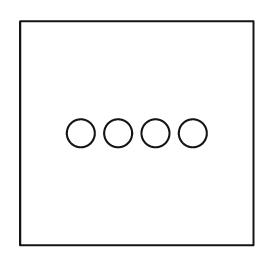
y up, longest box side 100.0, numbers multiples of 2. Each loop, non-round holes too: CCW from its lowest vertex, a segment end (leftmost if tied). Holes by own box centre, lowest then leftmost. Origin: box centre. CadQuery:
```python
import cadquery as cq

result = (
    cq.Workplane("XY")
    .moveTo(-50.0, -48.0)
    .lineTo(50.0, -48.0)
    .lineTo(50.0, 48.0)
    .lineTo(-50.0, 48.0)
    .close()
    .moveTo(-24.0, 0.0)
    .circle(6.0)
    .moveTo(-8.0, 0.0)
    .circle(6.0)
    .moveTo(8.0, 0.0)
    .circle(6.0)
    .moveTo(24.0, 0.0)
    .circle(6.0)
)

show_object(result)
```